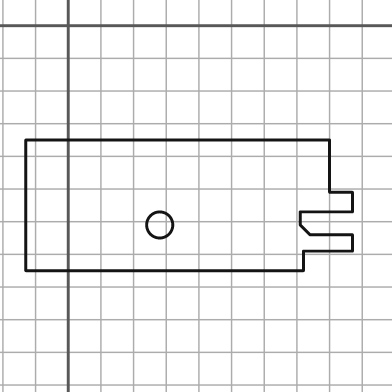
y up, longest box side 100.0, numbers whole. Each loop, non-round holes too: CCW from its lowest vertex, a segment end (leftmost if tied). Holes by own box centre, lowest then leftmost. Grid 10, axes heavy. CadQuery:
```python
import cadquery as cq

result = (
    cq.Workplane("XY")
    .moveTo(-13.0, -75.0)
    .lineTo(72.0, -75.0)
    .lineTo(72.0, -69.0)
    .lineTo(87.0, -69.0)
    .lineTo(87.0, -64.0)
    .lineTo(74.0, -64.0)
    .lineTo(71.0, -61.0)
    .lineTo(71.0, -57.0)
    .lineTo(87.0, -57.0)
    .lineTo(87.0, -51.0)
    .lineTo(80.0, -51.0)
    .lineTo(80.0, -35.0)
    .lineTo(-13.0, -35.0)
    .close()
    .moveTo(28.0, -61.0)
    .circle(4.0)
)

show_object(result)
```